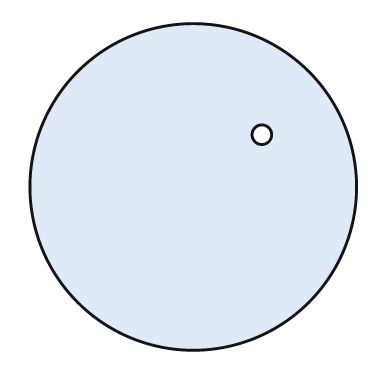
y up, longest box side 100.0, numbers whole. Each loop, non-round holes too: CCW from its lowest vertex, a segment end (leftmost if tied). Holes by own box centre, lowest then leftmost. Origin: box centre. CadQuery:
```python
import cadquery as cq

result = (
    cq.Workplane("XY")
    .moveTo(0.0, 0.0)
    .circle(50.0)
    .moveTo(21.0, 16.0)
    .circle(3.0)
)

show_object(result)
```